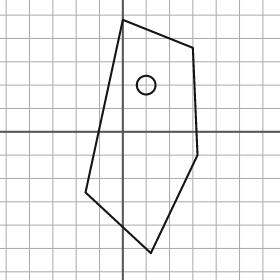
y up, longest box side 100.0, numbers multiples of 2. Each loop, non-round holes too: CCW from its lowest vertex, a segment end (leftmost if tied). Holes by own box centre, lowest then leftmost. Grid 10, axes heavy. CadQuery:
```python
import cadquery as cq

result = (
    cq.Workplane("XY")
    .moveTo(12.0, -52.0)
    .lineTo(32.0, -10.0)
    .lineTo(30.0, 36.0)
    .lineTo(0.0, 48.0)
    .lineTo(-16.0, -26.0)
    .close()
    .moveTo(10.0, 20.0)
    .circle(4.0)
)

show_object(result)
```